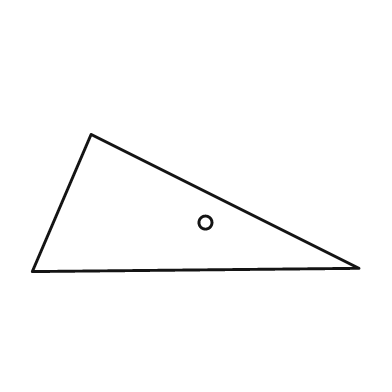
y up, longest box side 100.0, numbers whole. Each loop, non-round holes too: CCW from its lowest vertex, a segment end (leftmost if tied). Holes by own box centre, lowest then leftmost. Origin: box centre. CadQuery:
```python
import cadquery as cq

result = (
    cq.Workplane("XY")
    .moveTo(-50.0, -21.0)
    .lineTo(50.0, -20.0)
    .lineTo(-32.0, 21.0)
    .close()
    .moveTo(3.0, -6.0)
    .circle(2.0)
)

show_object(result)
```